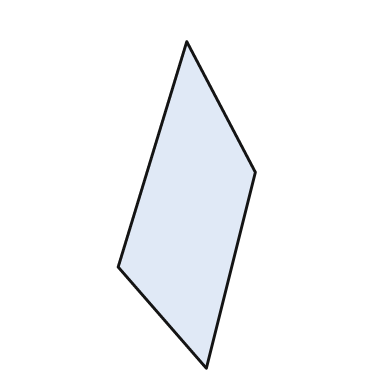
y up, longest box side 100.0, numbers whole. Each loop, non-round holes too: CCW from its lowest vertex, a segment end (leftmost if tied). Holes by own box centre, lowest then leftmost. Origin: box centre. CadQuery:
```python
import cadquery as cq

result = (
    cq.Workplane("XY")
    .moveTo(6.0, -50.0)
    .lineTo(21.0, 10.0)
    .lineTo(0.0, 50.0)
    .lineTo(-21.0, -19.0)
    .close()
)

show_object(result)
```